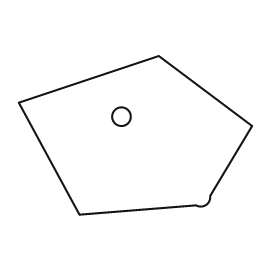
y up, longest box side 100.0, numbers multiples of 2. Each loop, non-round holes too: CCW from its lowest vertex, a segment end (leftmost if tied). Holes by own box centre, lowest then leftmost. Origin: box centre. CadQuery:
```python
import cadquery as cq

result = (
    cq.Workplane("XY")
    .moveTo(-24.0, -34.0)
    .lineTo(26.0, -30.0)
    .threePointArc((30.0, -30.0), (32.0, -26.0))
    .lineTo(50.0, 4.0)
    .lineTo(10.0, 34.0)
    .lineTo(-50.0, 14.0)
    .close()
    .moveTo(-6.0, 8.0)
    .circle(4.0)
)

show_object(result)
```